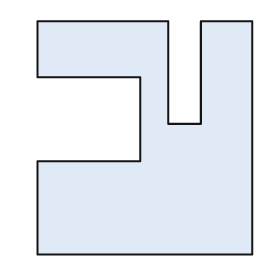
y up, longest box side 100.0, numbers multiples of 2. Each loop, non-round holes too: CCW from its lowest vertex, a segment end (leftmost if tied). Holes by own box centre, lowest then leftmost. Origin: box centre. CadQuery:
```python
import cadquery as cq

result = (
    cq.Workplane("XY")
    .moveTo(-46.0, -50.0)
    .lineTo(46.0, -50.0)
    .lineTo(46.0, 50.0)
    .lineTo(24.0, 50.0)
    .lineTo(24.0, 6.0)
    .lineTo(10.0, 6.0)
    .lineTo(10.0, 50.0)
    .lineTo(-46.0, 50.0)
    .lineTo(-46.0, 26.0)
    .lineTo(-2.0, 26.0)
    .lineTo(-2.0, -10.0)
    .lineTo(-46.0, -10.0)
    .close()
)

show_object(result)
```